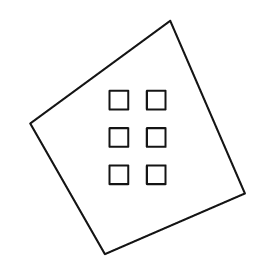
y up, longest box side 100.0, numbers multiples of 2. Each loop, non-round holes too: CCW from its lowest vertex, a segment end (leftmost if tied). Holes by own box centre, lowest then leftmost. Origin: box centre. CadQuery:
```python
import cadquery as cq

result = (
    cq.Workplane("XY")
    .moveTo(-14.0, -50.0)
    .lineTo(46.0, -24.0)
    .lineTo(14.0, 50.0)
    .lineTo(-46.0, 6.0)
    .close()
    .moveTo(-12.0, -20.0)
    .lineTo(-4.0, -20.0)
    .lineTo(-4.0, -12.0)
    .lineTo(-12.0, -12.0)
    .close()
    .moveTo(4.0, -20.0)
    .lineTo(12.0, -20.0)
    .lineTo(12.0, -12.0)
    .lineTo(4.0, -12.0)
    .close()
    .moveTo(-12.0, -4.0)
    .lineTo(-4.0, -4.0)
    .lineTo(-4.0, 4.0)
    .lineTo(-12.0, 4.0)
    .close()
    .moveTo(4.0, -4.0)
    .lineTo(12.0, -4.0)
    .lineTo(12.0, 4.0)
    .lineTo(4.0, 4.0)
    .close()
    .moveTo(-12.0, 12.0)
    .lineTo(-4.0, 12.0)
    .lineTo(-4.0, 20.0)
    .lineTo(-12.0, 20.0)
    .close()
    .moveTo(4.0, 12.0)
    .lineTo(12.0, 12.0)
    .lineTo(12.0, 20.0)
    .lineTo(4.0, 20.0)
    .close()
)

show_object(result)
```